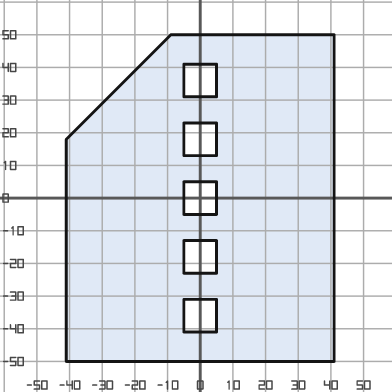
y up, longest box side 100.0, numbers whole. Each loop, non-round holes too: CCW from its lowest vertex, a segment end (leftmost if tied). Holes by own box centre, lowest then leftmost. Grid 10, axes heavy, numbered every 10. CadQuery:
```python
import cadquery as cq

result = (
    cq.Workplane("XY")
    .moveTo(-41.0, -50.0)
    .lineTo(41.0, -50.0)
    .lineTo(41.0, 50.0)
    .lineTo(-9.0, 50.0)
    .lineTo(-41.0, 18.0)
    .close()
    .moveTo(-5.0, -41.0)
    .lineTo(5.0, -41.0)
    .lineTo(5.0, -31.0)
    .lineTo(-5.0, -31.0)
    .close()
    .moveTo(-5.0, -23.0)
    .lineTo(5.0, -23.0)
    .lineTo(5.0, -13.0)
    .lineTo(-5.0, -13.0)
    .close()
    .moveTo(-5.0, -5.0)
    .lineTo(5.0, -5.0)
    .lineTo(5.0, 5.0)
    .lineTo(-5.0, 5.0)
    .close()
    .moveTo(-5.0, 13.0)
    .lineTo(5.0, 13.0)
    .lineTo(5.0, 23.0)
    .lineTo(-5.0, 23.0)
    .close()
    .moveTo(-5.0, 31.0)
    .lineTo(5.0, 31.0)
    .lineTo(5.0, 41.0)
    .lineTo(-5.0, 41.0)
    .close()
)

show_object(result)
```